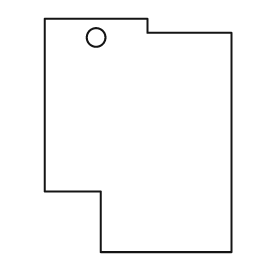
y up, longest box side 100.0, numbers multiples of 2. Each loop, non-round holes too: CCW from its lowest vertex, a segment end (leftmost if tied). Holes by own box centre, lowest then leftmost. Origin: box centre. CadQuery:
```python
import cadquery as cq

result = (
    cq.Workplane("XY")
    .moveTo(-16.0, -50.0)
    .lineTo(40.0, -50.0)
    .lineTo(40.0, 44.0)
    .lineTo(4.0, 44.0)
    .lineTo(4.0, 50.0)
    .lineTo(-40.0, 50.0)
    .lineTo(-40.0, -24.0)
    .lineTo(-16.0, -24.0)
    .close()
    .moveTo(-18.0, 42.0)
    .circle(4.0)
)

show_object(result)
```